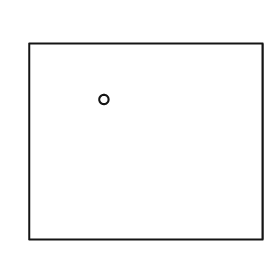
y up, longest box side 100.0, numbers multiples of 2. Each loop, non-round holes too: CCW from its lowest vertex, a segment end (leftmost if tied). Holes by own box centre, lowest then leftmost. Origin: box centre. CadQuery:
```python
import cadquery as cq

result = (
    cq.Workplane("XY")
    .moveTo(-50.0, -42.0)
    .lineTo(50.0, -42.0)
    .lineTo(50.0, 42.0)
    .lineTo(-50.0, 42.0)
    .close()
    .moveTo(-18.0, 18.0)
    .circle(2.0)
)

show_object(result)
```